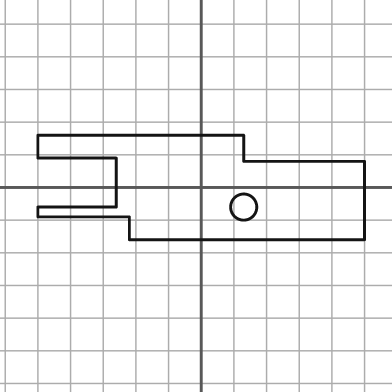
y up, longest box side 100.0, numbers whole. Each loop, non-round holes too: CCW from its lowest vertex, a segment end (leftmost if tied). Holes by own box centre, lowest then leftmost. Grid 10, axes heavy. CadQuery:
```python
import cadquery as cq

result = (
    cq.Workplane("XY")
    .moveTo(-22.0, -16.0)
    .lineTo(50.0, -16.0)
    .lineTo(50.0, 8.0)
    .lineTo(13.0, 8.0)
    .lineTo(13.0, 16.0)
    .lineTo(-50.0, 16.0)
    .lineTo(-50.0, 9.0)
    .lineTo(-26.0, 9.0)
    .lineTo(-26.0, -6.0)
    .lineTo(-50.0, -6.0)
    .lineTo(-50.0, -9.0)
    .lineTo(-22.0, -9.0)
    .close()
    .moveTo(13.0, -6.0)
    .circle(4.0)
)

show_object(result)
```